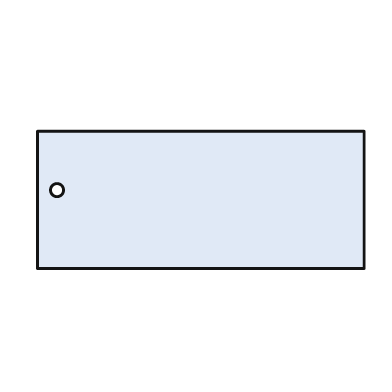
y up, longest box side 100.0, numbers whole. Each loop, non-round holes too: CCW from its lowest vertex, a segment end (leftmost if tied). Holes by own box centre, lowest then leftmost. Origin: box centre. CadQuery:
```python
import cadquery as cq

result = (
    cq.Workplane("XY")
    .moveTo(-50.0, -21.0)
    .lineTo(50.0, -21.0)
    .lineTo(50.0, 21.0)
    .lineTo(-50.0, 21.0)
    .close()
    .moveTo(-44.0, 3.0)
    .circle(2.0)
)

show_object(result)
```